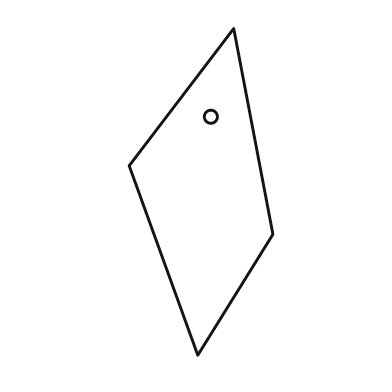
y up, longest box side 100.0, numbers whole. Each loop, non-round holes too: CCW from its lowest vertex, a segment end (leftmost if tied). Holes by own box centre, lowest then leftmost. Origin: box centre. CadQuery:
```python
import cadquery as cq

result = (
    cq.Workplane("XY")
    .moveTo(-1.0, -50.0)
    .lineTo(22.0, -13.0)
    .lineTo(10.0, 50.0)
    .lineTo(-22.0, 8.0)
    .close()
    .moveTo(3.0, 23.0)
    .circle(2.0)
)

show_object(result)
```